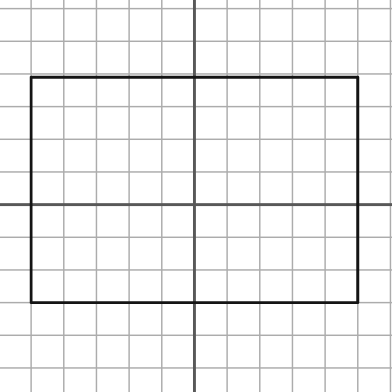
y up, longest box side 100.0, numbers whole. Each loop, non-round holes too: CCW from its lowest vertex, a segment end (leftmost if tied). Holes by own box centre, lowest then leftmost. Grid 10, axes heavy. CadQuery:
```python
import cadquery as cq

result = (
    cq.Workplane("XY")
    .moveTo(-50.0, -30.0)
    .lineTo(50.0, -30.0)
    .lineTo(50.0, 39.0)
    .lineTo(-50.0, 39.0)
    .close()
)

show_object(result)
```